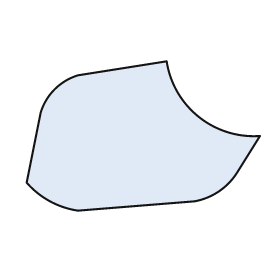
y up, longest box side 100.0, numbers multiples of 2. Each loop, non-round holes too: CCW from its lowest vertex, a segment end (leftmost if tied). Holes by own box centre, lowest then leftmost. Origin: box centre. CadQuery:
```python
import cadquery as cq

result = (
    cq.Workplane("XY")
    .moveTo(-28.0, -32.0)
    .lineTo(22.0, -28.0)
    .threePointArc((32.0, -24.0), (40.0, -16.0))
    .lineTo(50.0, 0.0)
    .threePointArc((24.0, 8.0), (10.0, 32.0))
    .lineTo(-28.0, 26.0)
    .threePointArc((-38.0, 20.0), (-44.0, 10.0))
    .lineTo(-50.0, -20.0)
    .threePointArc((-40.0, -28.0), (-28.0, -32.0))
    .close()
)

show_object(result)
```